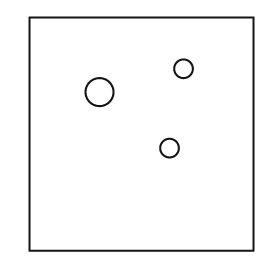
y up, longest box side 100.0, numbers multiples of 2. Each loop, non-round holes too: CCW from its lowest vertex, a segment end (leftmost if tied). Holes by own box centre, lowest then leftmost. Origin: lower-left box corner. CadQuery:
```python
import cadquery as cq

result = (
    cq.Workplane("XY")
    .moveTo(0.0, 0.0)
    .lineTo(96.0, 0.0)
    .lineTo(96.0, 100.0)
    .lineTo(0.0, 100.0)
    .close()
    .moveTo(60.0, 44.0)
    .circle(4.0)
    .moveTo(30.0, 68.0)
    .circle(6.0)
    .moveTo(66.0, 78.0)
    .circle(4.0)
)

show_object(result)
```